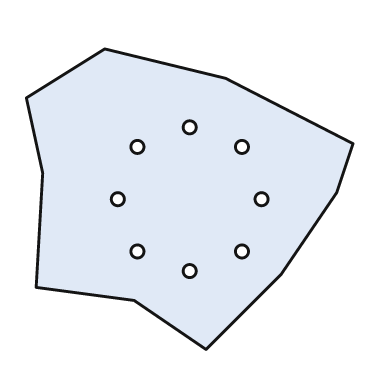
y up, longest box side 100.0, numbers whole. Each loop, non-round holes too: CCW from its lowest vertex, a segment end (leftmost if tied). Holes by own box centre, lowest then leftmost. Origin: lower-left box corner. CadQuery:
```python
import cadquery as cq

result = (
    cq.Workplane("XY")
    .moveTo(55.0, 0.0)
    .lineTo(78.0, 23.0)
    .lineTo(95.0, 48.0)
    .lineTo(100.0, 63.0)
    .lineTo(61.0, 83.0)
    .lineTo(24.0, 92.0)
    .lineTo(0.0, 77.0)
    .lineTo(5.0, 54.0)
    .lineTo(3.0, 19.0)
    .lineTo(33.0, 15.0)
    .close()
    .moveTo(50.0, 24.0)
    .circle(2.0)
    .moveTo(34.0, 30.0)
    .circle(2.0)
    .moveTo(66.0, 30.0)
    .circle(2.0)
    .moveTo(28.0, 46.0)
    .circle(2.0)
    .moveTo(72.0, 46.0)
    .circle(2.0)
    .moveTo(34.0, 62.0)
    .circle(2.0)
    .moveTo(66.0, 62.0)
    .circle(2.0)
    .moveTo(50.0, 68.0)
    .circle(2.0)
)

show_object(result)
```